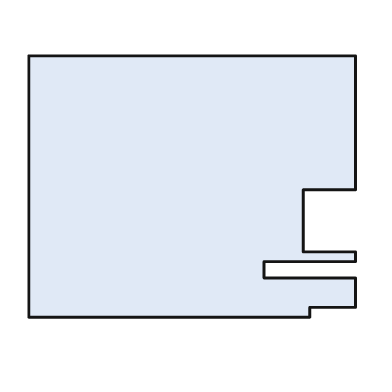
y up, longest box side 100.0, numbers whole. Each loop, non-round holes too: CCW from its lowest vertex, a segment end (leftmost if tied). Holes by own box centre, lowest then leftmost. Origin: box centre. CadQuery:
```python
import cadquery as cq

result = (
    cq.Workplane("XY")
    .moveTo(-50.0, -40.0)
    .lineTo(36.0, -40.0)
    .lineTo(36.0, -37.0)
    .lineTo(50.0, -37.0)
    .lineTo(50.0, -28.0)
    .lineTo(22.0, -28.0)
    .lineTo(22.0, -23.0)
    .lineTo(50.0, -23.0)
    .lineTo(50.0, -20.0)
    .lineTo(34.0, -20.0)
    .lineTo(34.0, -1.0)
    .lineTo(50.0, -1.0)
    .lineTo(50.0, 40.0)
    .lineTo(-50.0, 40.0)
    .close()
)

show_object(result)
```